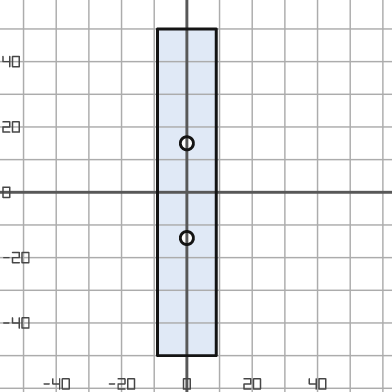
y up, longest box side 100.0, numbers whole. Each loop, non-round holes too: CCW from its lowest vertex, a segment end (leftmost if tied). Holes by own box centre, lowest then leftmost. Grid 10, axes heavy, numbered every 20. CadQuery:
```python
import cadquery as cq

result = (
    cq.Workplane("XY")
    .moveTo(-9.0, -50.0)
    .lineTo(9.0, -50.0)
    .lineTo(9.0, 50.0)
    .lineTo(-9.0, 50.0)
    .close()
    .moveTo(0.0, -14.0)
    .circle(2.0)
    .moveTo(0.0, 15.0)
    .circle(2.0)
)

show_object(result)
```